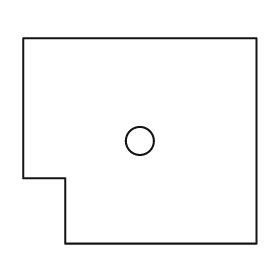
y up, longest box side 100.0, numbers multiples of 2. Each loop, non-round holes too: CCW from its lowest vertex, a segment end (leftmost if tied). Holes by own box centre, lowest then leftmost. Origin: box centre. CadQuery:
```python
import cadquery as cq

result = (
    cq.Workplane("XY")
    .moveTo(-32.0, -44.0)
    .lineTo(50.0, -44.0)
    .lineTo(50.0, 44.0)
    .lineTo(-50.0, 44.0)
    .lineTo(-50.0, -16.0)
    .lineTo(-32.0, -16.0)
    .close()
    .moveTo(0.0, 0.0)
    .circle(6.0)
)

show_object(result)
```